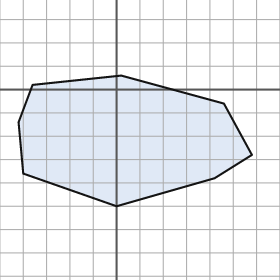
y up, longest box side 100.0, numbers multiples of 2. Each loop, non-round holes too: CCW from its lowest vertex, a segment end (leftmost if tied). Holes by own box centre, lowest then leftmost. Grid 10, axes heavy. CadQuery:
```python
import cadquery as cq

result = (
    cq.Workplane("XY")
    .moveTo(0.0, -50.0)
    .lineTo(42.0, -38.0)
    .lineTo(58.0, -28.0)
    .lineTo(46.0, -6.0)
    .lineTo(2.0, 6.0)
    .lineTo(-36.0, 2.0)
    .lineTo(-42.0, -14.0)
    .lineTo(-40.0, -36.0)
    .close()
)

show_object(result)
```